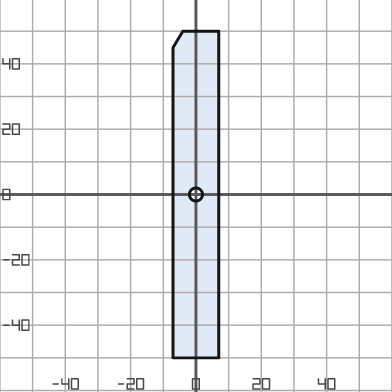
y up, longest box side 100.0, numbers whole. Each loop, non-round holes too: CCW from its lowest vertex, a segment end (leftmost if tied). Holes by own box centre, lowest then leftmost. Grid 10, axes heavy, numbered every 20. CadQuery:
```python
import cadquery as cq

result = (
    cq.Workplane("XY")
    .moveTo(-7.0, -50.0)
    .lineTo(7.0, -50.0)
    .lineTo(7.0, 50.0)
    .lineTo(-4.0, 50.0)
    .lineTo(-7.0, 45.0)
    .close()
    .moveTo(0.0, 0.0)
    .circle(2.0)
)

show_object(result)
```